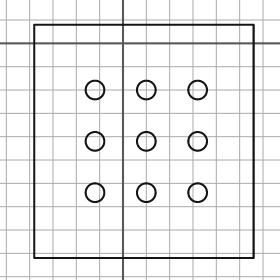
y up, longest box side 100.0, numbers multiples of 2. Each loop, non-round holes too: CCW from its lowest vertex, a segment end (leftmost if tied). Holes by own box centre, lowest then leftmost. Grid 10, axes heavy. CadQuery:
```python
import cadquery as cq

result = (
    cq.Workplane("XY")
    .moveTo(-38.0, -92.0)
    .lineTo(56.0, -92.0)
    .lineTo(56.0, 8.0)
    .lineTo(-38.0, 8.0)
    .close()
    .moveTo(-12.0, -64.0)
    .circle(4.0)
    .moveTo(10.0, -64.0)
    .circle(4.0)
    .moveTo(32.0, -64.0)
    .circle(4.0)
    .moveTo(-12.0, -42.0)
    .circle(4.0)
    .moveTo(10.0, -42.0)
    .circle(4.0)
    .moveTo(32.0, -42.0)
    .circle(4.0)
    .moveTo(-12.0, -20.0)
    .circle(4.0)
    .moveTo(10.0, -20.0)
    .circle(4.0)
    .moveTo(32.0, -20.0)
    .circle(4.0)
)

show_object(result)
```